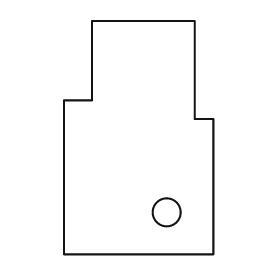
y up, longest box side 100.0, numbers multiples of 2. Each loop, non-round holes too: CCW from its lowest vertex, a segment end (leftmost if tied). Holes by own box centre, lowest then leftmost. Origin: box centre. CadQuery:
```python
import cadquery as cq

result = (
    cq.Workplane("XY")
    .moveTo(-32.0, -50.0)
    .lineTo(32.0, -50.0)
    .lineTo(32.0, 8.0)
    .lineTo(24.0, 8.0)
    .lineTo(24.0, 50.0)
    .lineTo(-20.0, 50.0)
    .lineTo(-20.0, 16.0)
    .lineTo(-32.0, 16.0)
    .close()
    .moveTo(12.0, -32.0)
    .circle(6.0)
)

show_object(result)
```